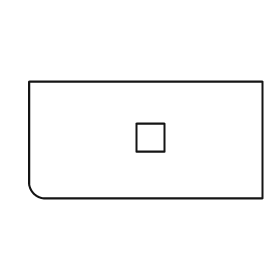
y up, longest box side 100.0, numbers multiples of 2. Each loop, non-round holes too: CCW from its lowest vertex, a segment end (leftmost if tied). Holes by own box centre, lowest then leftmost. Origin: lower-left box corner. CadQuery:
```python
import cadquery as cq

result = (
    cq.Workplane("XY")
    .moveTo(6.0, 0.0)
    .lineTo(100.0, 0.0)
    .lineTo(100.0, 50.0)
    .lineTo(0.0, 50.0)
    .lineTo(0.0, 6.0)
    .threePointArc((2.0, 2.0), (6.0, 0.0))
    .close()
    .moveTo(46.0, 20.0)
    .lineTo(58.0, 20.0)
    .lineTo(58.0, 32.0)
    .lineTo(46.0, 32.0)
    .close()
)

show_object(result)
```